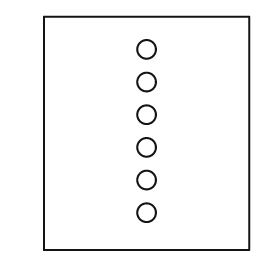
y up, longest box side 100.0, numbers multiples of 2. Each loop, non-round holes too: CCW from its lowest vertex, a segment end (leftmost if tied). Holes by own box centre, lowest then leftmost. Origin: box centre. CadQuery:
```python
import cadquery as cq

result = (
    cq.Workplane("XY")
    .moveTo(-44.0, -50.0)
    .lineTo(44.0, -50.0)
    .lineTo(44.0, 50.0)
    .lineTo(-44.0, 50.0)
    .close()
    .moveTo(0.0, -34.0)
    .circle(4.0)
    .moveTo(0.0, -20.0)
    .circle(4.0)
    .moveTo(0.0, -6.0)
    .circle(4.0)
    .moveTo(0.0, 8.0)
    .circle(4.0)
    .moveTo(0.0, 22.0)
    .circle(4.0)
    .moveTo(0.0, 36.0)
    .circle(4.0)
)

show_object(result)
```